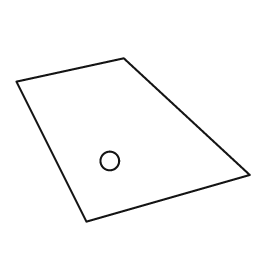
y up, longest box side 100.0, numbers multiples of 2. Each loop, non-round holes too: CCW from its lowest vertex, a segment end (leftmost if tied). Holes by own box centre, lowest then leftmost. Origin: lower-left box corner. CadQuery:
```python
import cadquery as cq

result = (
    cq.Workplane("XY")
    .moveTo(30.0, 0.0)
    .lineTo(100.0, 20.0)
    .lineTo(46.0, 70.0)
    .lineTo(0.0, 60.0)
    .close()
    .moveTo(40.0, 26.0)
    .circle(4.0)
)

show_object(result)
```